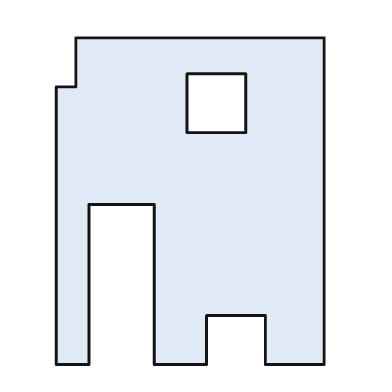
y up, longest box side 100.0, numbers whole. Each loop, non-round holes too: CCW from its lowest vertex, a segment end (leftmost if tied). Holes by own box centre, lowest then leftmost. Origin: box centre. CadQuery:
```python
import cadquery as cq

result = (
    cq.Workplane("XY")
    .moveTo(-41.0, -50.0)
    .lineTo(-31.0, -50.0)
    .lineTo(-31.0, -1.0)
    .lineTo(-11.0, -1.0)
    .lineTo(-11.0, -50.0)
    .lineTo(5.0, -50.0)
    .lineTo(5.0, -35.0)
    .lineTo(23.0, -35.0)
    .lineTo(23.0, -50.0)
    .lineTo(41.0, -50.0)
    .lineTo(41.0, 50.0)
    .lineTo(-35.0, 50.0)
    .lineTo(-35.0, 35.0)
    .lineTo(-41.0, 35.0)
    .close()
    .moveTo(-1.0, 21.0)
    .lineTo(17.0, 21.0)
    .lineTo(17.0, 39.0)
    .lineTo(-1.0, 39.0)
    .close()
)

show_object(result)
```